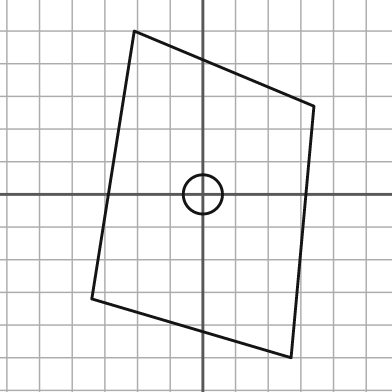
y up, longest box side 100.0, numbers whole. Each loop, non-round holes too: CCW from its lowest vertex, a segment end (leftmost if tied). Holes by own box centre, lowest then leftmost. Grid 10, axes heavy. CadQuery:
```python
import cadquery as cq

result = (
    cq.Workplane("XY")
    .moveTo(27.0, -50.0)
    .lineTo(34.0, 27.0)
    .lineTo(-21.0, 50.0)
    .lineTo(-34.0, -32.0)
    .close()
    .moveTo(0.0, 0.0)
    .circle(6.0)
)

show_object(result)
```